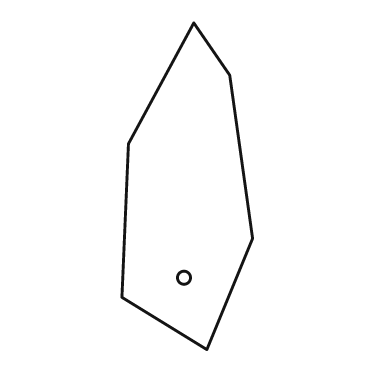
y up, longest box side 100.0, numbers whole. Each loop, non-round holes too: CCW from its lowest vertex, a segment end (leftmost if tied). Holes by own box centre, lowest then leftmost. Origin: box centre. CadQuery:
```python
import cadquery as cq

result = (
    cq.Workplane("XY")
    .moveTo(6.0, -50.0)
    .lineTo(20.0, -16.0)
    .lineTo(13.0, 34.0)
    .lineTo(2.0, 50.0)
    .lineTo(-18.0, 13.0)
    .lineTo(-20.0, -34.0)
    .close()
    .moveTo(-1.0, -28.0)
    .circle(2.0)
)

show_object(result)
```